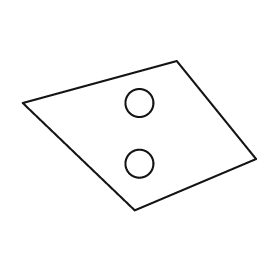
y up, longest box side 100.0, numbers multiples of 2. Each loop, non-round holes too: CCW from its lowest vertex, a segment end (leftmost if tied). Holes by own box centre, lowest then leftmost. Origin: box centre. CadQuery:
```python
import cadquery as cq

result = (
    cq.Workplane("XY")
    .moveTo(-2.0, -32.0)
    .lineTo(50.0, -10.0)
    .lineTo(16.0, 32.0)
    .lineTo(-50.0, 14.0)
    .close()
    .moveTo(0.0, -12.0)
    .circle(6.0)
    .moveTo(0.0, 14.0)
    .circle(6.0)
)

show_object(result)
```